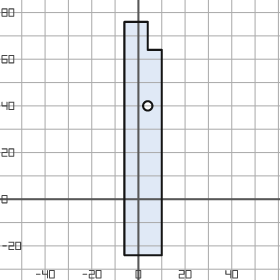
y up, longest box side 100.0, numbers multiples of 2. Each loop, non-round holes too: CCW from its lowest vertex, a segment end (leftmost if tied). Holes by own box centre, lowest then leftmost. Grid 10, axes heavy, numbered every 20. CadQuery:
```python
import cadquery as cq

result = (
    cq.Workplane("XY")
    .moveTo(-6.0, -24.0)
    .lineTo(10.0, -24.0)
    .lineTo(10.0, 64.0)
    .lineTo(4.0, 64.0)
    .lineTo(4.0, 76.0)
    .lineTo(-6.0, 76.0)
    .close()
    .moveTo(4.0, 40.0)
    .circle(2.0)
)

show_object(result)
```